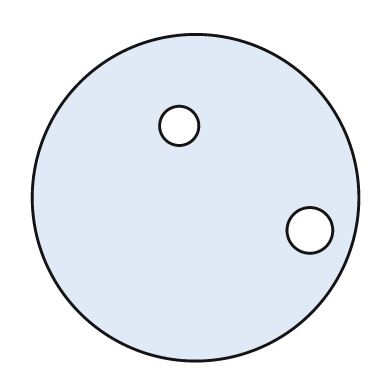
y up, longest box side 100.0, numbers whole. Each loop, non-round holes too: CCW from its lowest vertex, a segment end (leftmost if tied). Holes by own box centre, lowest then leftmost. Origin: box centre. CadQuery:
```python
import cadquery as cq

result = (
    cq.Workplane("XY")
    .moveTo(0.0, 0.0)
    .circle(50.0)
    .moveTo(35.0, -10.0)
    .circle(7.0)
    .moveTo(-5.0, 22.0)
    .circle(6.0)
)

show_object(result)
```